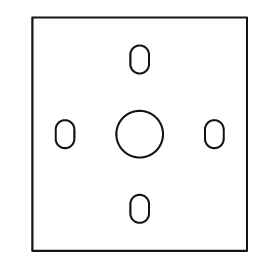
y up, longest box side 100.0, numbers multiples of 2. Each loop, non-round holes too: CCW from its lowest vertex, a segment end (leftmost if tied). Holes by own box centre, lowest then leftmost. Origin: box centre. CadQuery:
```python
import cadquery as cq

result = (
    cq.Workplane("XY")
    .moveTo(-46.0, -50.0)
    .lineTo(46.0, -50.0)
    .lineTo(46.0, 50.0)
    .lineTo(-46.0, 50.0)
    .close()
    .moveTo(-4.0, -34.0)
    .threePointArc((0.0, -38.0), (4.0, -34.0))
    .lineTo(4.0, -30.0)
    .threePointArc((0.0, -26.0), (-4.0, -30.0))
    .close()
    .moveTo(-36.0, -2.0)
    .threePointArc((-32.0, -6.0), (-28.0, -2.0))
    .lineTo(-28.0, 2.0)
    .threePointArc((-32.0, 6.0), (-36.0, 2.0))
    .close()
    .moveTo(0.0, 0.0)
    .circle(10.0)
    .moveTo(28.0, -2.0)
    .threePointArc((32.0, -6.0), (36.0, -2.0))
    .lineTo(36.0, 2.0)
    .threePointArc((32.0, 6.0), (28.0, 2.0))
    .close()
    .moveTo(-4.0, 30.0)
    .threePointArc((0.0, 26.0), (4.0, 30.0))
    .lineTo(4.0, 34.0)
    .threePointArc((0.0, 38.0), (-4.0, 34.0))
    .close()
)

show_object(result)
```